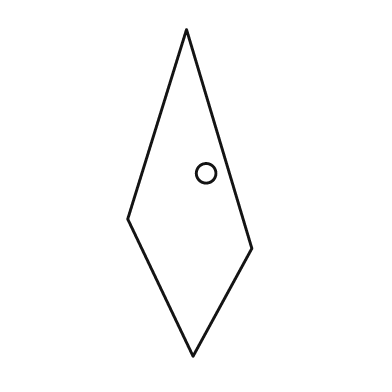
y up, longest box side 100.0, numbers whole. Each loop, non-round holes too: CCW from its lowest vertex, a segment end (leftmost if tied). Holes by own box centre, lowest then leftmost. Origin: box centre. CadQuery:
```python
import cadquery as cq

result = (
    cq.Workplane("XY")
    .moveTo(1.0, -50.0)
    .lineTo(19.0, -17.0)
    .lineTo(-1.0, 50.0)
    .lineTo(-19.0, -8.0)
    .close()
    .moveTo(5.0, 6.0)
    .circle(3.0)
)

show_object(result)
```